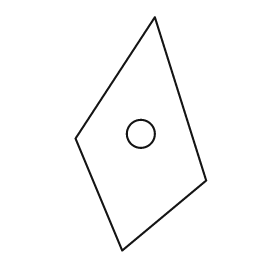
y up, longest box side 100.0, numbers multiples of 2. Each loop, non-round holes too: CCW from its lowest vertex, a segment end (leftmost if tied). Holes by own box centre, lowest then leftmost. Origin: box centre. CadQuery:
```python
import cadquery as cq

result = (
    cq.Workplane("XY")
    .moveTo(-8.0, -50.0)
    .lineTo(28.0, -20.0)
    .lineTo(6.0, 50.0)
    .lineTo(-28.0, -2.0)
    .close()
    .moveTo(0.0, 0.0)
    .circle(6.0)
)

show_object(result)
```